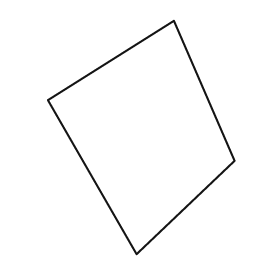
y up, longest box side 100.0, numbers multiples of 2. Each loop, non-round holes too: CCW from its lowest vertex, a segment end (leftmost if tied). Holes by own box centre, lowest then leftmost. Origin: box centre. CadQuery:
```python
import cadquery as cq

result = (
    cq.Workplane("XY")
    .moveTo(-2.0, -50.0)
    .lineTo(40.0, -10.0)
    .lineTo(14.0, 50.0)
    .lineTo(-40.0, 16.0)
    .close()
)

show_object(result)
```